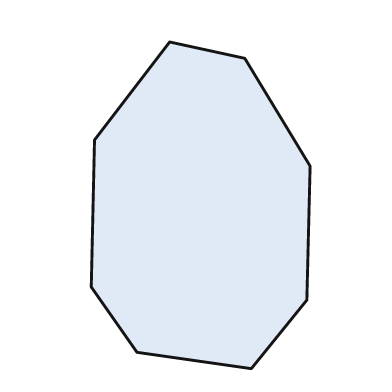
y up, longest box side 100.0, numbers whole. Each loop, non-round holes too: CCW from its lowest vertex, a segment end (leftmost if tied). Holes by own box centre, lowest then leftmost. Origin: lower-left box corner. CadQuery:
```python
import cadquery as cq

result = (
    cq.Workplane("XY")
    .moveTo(49.0, 0.0)
    .lineTo(66.0, 21.0)
    .lineTo(67.0, 62.0)
    .lineTo(47.0, 95.0)
    .lineTo(24.0, 100.0)
    .lineTo(1.0, 70.0)
    .lineTo(0.0, 25.0)
    .lineTo(14.0, 5.0)
    .close()
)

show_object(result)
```